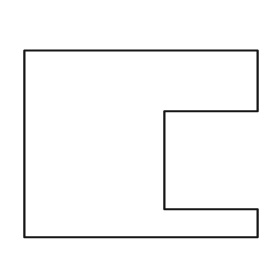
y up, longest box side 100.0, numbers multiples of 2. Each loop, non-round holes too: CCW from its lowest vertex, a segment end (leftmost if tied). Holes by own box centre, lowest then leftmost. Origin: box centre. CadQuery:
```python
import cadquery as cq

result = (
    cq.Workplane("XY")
    .moveTo(-50.0, -40.0)
    .lineTo(50.0, -40.0)
    .lineTo(50.0, -28.0)
    .lineTo(10.0, -28.0)
    .lineTo(10.0, 14.0)
    .lineTo(50.0, 14.0)
    .lineTo(50.0, 40.0)
    .lineTo(-50.0, 40.0)
    .close()
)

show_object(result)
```